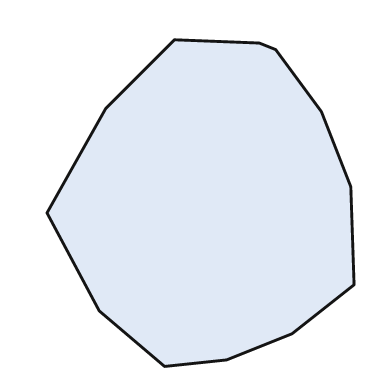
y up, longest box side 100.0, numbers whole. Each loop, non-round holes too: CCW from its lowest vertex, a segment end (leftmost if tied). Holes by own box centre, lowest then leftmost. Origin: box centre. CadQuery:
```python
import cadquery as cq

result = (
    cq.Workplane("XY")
    .moveTo(-11.0, -50.0)
    .lineTo(8.0, -48.0)
    .lineTo(28.0, -40.0)
    .lineTo(47.0, -25.0)
    .lineTo(46.0, 5.0)
    .lineTo(37.0, 28.0)
    .lineTo(23.0, 47.0)
    .lineTo(18.0, 49.0)
    .lineTo(-8.0, 50.0)
    .lineTo(-29.0, 29.0)
    .lineTo(-47.0, -3.0)
    .lineTo(-31.0, -33.0)
    .close()
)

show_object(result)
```